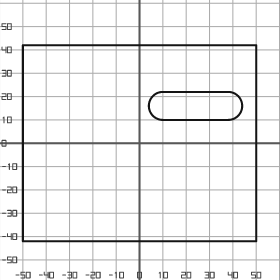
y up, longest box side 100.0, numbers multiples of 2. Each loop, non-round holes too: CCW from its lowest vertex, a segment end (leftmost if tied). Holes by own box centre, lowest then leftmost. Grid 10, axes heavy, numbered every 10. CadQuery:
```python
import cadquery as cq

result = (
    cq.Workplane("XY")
    .moveTo(-50.0, -42.0)
    .lineTo(50.0, -42.0)
    .lineTo(50.0, 42.0)
    .lineTo(-50.0, 42.0)
    .close()
    .moveTo(10.0, 10.0)
    .lineTo(38.0, 10.0)
    .threePointArc((44.0, 16.0), (38.0, 22.0))
    .lineTo(10.0, 22.0)
    .threePointArc((4.0, 16.0), (10.0, 10.0))
    .close()
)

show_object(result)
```